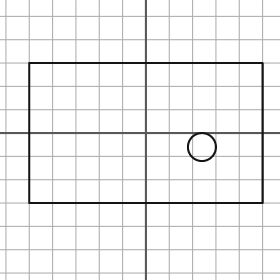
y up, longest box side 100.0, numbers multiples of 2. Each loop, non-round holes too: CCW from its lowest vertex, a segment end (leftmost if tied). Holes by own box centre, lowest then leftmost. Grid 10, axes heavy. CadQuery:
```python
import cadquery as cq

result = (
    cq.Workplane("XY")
    .moveTo(-50.0, -30.0)
    .lineTo(50.0, -30.0)
    .lineTo(50.0, 30.0)
    .lineTo(-50.0, 30.0)
    .close()
    .moveTo(24.0, -6.0)
    .circle(6.0)
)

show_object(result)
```